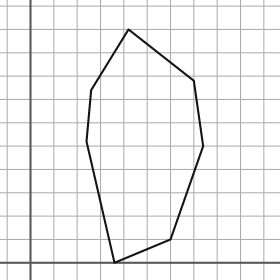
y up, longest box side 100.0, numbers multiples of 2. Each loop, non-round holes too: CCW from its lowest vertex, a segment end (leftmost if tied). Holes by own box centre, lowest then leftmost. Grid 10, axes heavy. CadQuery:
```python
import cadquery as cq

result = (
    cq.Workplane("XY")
    .moveTo(36.0, 0.0)
    .lineTo(60.0, 10.0)
    .lineTo(74.0, 50.0)
    .lineTo(70.0, 78.0)
    .lineTo(42.0, 100.0)
    .lineTo(26.0, 74.0)
    .lineTo(24.0, 52.0)
    .close()
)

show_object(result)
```